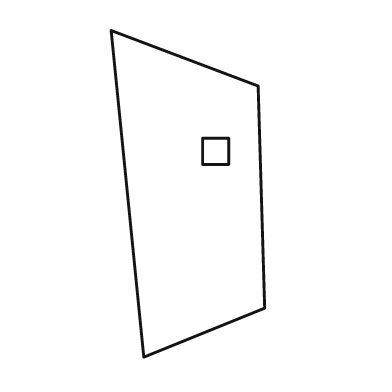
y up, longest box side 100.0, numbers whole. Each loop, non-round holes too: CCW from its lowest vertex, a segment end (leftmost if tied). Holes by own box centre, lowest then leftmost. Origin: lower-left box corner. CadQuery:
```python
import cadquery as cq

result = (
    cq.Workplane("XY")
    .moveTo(10.0, 0.0)
    .lineTo(47.0, 15.0)
    .lineTo(45.0, 83.0)
    .lineTo(0.0, 100.0)
    .close()
    .moveTo(28.0, 59.0)
    .lineTo(36.0, 59.0)
    .lineTo(36.0, 67.0)
    .lineTo(28.0, 67.0)
    .close()
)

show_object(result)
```